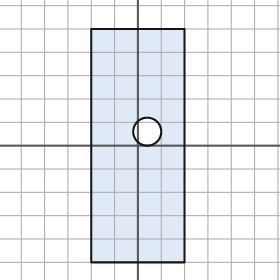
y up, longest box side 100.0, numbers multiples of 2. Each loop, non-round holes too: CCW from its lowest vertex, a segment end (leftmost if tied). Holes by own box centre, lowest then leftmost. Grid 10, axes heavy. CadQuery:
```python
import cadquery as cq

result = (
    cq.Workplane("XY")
    .moveTo(-20.0, -50.0)
    .lineTo(20.0, -50.0)
    .lineTo(20.0, 50.0)
    .lineTo(-20.0, 50.0)
    .close()
    .moveTo(4.0, 6.0)
    .circle(6.0)
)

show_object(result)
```